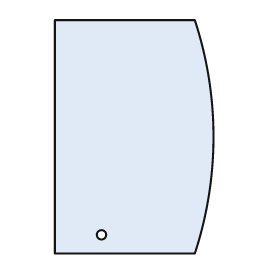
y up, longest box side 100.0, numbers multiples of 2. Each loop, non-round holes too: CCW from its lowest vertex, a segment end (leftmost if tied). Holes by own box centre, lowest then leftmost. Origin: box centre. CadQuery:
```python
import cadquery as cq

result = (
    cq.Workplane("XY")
    .moveTo(-34.0, -50.0)
    .lineTo(26.0, -50.0)
    .threePointArc((34.0, 0.0), (26.0, 50.0))
    .lineTo(-34.0, 50.0)
    .close()
    .moveTo(-14.0, -42.0)
    .circle(2.0)
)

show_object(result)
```